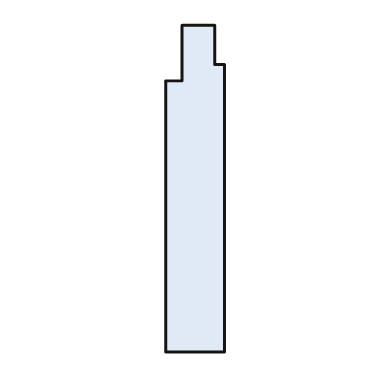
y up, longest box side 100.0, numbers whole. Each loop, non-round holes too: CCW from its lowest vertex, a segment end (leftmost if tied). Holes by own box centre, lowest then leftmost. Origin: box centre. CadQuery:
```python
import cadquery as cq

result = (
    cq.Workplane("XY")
    .moveTo(-9.0, -50.0)
    .lineTo(9.0, -50.0)
    .lineTo(9.0, 38.0)
    .lineTo(6.0, 38.0)
    .lineTo(6.0, 50.0)
    .lineTo(-4.0, 50.0)
    .lineTo(-4.0, 33.0)
    .lineTo(-9.0, 33.0)
    .close()
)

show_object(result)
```